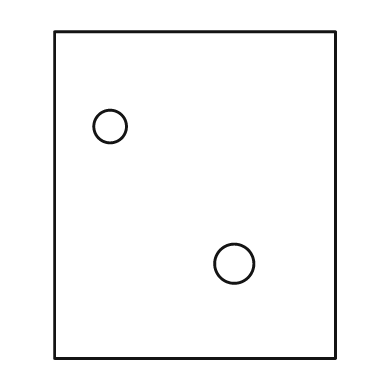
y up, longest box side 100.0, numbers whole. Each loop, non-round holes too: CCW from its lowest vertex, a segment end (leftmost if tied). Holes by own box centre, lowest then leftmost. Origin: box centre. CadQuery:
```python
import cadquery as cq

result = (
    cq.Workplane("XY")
    .moveTo(-43.0, -50.0)
    .lineTo(43.0, -50.0)
    .lineTo(43.0, 50.0)
    .lineTo(-43.0, 50.0)
    .close()
    .moveTo(12.0, -21.0)
    .circle(6.0)
    .moveTo(-26.0, 21.0)
    .circle(5.0)
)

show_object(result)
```